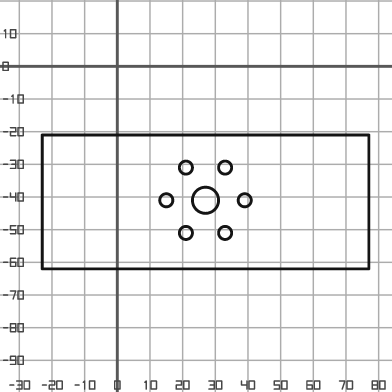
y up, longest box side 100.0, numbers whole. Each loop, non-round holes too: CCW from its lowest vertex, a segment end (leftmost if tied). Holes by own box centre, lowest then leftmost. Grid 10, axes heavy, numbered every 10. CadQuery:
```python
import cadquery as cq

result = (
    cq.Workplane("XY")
    .moveTo(-23.0, -62.0)
    .lineTo(77.0, -62.0)
    .lineTo(77.0, -21.0)
    .lineTo(-23.0, -21.0)
    .close()
    .moveTo(21.0, -51.0)
    .circle(2.0)
    .moveTo(33.0, -51.0)
    .circle(2.0)
    .moveTo(15.0, -41.0)
    .circle(2.0)
    .moveTo(27.0, -41.0)
    .circle(4.0)
    .moveTo(39.0, -41.0)
    .circle(2.0)
    .moveTo(21.0, -31.0)
    .circle(2.0)
    .moveTo(33.0, -31.0)
    .circle(2.0)
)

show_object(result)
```